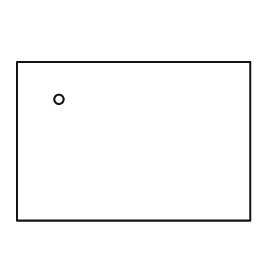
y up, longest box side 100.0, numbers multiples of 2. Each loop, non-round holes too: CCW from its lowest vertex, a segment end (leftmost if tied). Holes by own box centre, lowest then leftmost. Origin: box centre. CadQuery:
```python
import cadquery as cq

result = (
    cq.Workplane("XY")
    .moveTo(-50.0, -34.0)
    .lineTo(50.0, -34.0)
    .lineTo(50.0, 34.0)
    .lineTo(-50.0, 34.0)
    .close()
    .moveTo(-32.0, 18.0)
    .circle(2.0)
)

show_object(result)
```